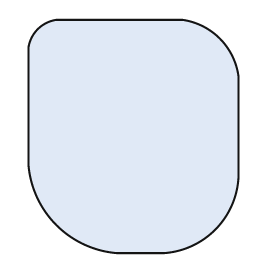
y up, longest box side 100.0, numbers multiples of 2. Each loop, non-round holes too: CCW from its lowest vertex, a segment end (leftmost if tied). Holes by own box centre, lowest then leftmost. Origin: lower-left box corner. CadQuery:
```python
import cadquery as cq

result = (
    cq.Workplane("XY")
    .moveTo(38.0, 0.0)
    .lineTo(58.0, 0.0)
    .threePointArc((80.0, 10.0), (90.0, 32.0))
    .lineTo(90.0, 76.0)
    .threePointArc((82.0, 92.0), (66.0, 100.0))
    .lineTo(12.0, 100.0)
    .threePointArc((4.0, 96.0), (0.0, 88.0))
    .lineTo(0.0, 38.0)
    .threePointArc((12.0, 12.0), (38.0, 0.0))
    .close()
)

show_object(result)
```